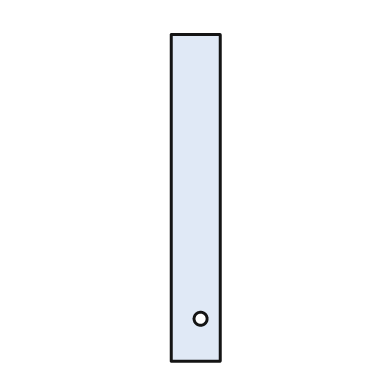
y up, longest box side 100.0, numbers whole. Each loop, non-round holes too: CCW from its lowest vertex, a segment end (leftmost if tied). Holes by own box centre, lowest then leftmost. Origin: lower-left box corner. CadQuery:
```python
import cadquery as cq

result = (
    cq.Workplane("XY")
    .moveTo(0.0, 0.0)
    .lineTo(15.0, 0.0)
    .lineTo(15.0, 100.0)
    .lineTo(0.0, 100.0)
    .close()
    .moveTo(9.0, 13.0)
    .circle(2.0)
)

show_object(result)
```